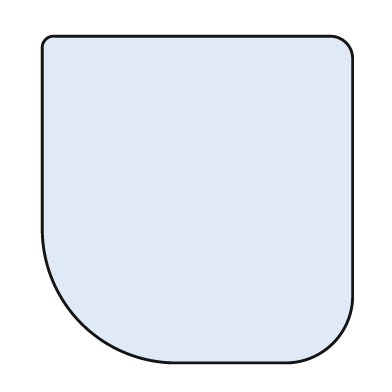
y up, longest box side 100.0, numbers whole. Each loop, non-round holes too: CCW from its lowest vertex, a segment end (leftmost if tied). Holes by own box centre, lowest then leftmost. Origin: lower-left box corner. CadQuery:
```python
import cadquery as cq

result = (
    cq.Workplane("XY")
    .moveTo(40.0, 0.0)
    .lineTo(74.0, 0.0)
    .threePointArc((89.0, 6.0), (95.0, 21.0))
    .lineTo(95.0, 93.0)
    .threePointArc((93.0, 98.0), (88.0, 100.0))
    .lineTo(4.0, 100.0)
    .threePointArc((1.0, 99.0), (0.0, 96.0))
    .lineTo(0.0, 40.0)
    .threePointArc((12.0, 12.0), (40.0, 0.0))
    .close()
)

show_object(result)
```